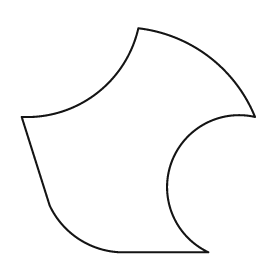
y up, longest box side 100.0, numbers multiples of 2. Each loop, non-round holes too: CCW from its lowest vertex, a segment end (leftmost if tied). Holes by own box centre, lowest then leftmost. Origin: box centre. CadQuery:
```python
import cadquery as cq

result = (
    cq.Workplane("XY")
    .moveTo(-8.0, -48.0)
    .lineTo(30.0, -48.0)
    .threePointArc((14.0, -10.0), (50.0, 10.0))
    .threePointArc((30.0, 36.0), (0.0, 48.0))
    .threePointArc((-18.0, 20.0), (-50.0, 10.0))
    .lineTo(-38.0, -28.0)
    .threePointArc((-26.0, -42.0), (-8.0, -48.0))
    .close()
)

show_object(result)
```